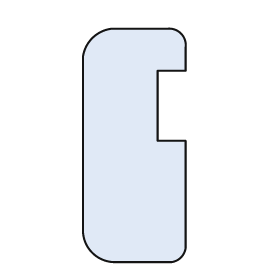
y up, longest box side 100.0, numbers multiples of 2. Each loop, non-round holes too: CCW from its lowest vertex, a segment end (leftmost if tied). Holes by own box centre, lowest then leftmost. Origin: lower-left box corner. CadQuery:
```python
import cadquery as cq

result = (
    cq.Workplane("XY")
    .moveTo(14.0, 0.0)
    .lineTo(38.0, 0.0)
    .threePointArc((42.0, 2.0), (44.0, 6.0))
    .lineTo(44.0, 52.0)
    .lineTo(32.0, 52.0)
    .lineTo(32.0, 82.0)
    .lineTo(44.0, 82.0)
    .lineTo(44.0, 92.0)
    .threePointArc((42.0, 98.0), (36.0, 100.0))
    .lineTo(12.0, 100.0)
    .threePointArc((4.0, 96.0), (0.0, 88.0))
    .lineTo(0.0, 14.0)
    .threePointArc((4.0, 4.0), (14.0, 0.0))
    .close()
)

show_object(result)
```